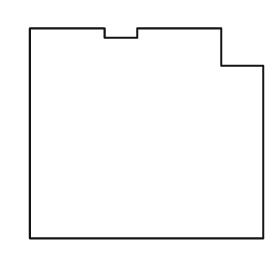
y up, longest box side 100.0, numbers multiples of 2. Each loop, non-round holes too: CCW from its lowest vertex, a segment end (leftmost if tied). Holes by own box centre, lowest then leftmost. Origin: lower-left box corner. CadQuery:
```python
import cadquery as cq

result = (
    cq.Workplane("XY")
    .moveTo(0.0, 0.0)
    .lineTo(100.0, 0.0)
    .lineTo(100.0, 74.0)
    .lineTo(82.0, 74.0)
    .lineTo(82.0, 90.0)
    .lineTo(46.0, 90.0)
    .lineTo(46.0, 86.0)
    .lineTo(32.0, 86.0)
    .lineTo(32.0, 90.0)
    .lineTo(0.0, 90.0)
    .close()
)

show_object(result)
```